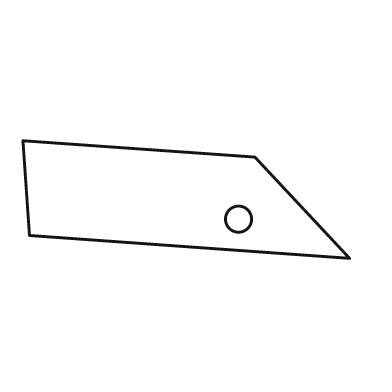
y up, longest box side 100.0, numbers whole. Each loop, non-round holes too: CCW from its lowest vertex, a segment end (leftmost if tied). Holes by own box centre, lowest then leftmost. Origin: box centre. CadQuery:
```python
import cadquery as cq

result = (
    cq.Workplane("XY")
    .moveTo(50.0, -18.0)
    .lineTo(21.0, 13.0)
    .lineTo(-50.0, 18.0)
    .lineTo(-48.0, -11.0)
    .close()
    .moveTo(16.0, -6.0)
    .circle(4.0)
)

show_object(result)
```